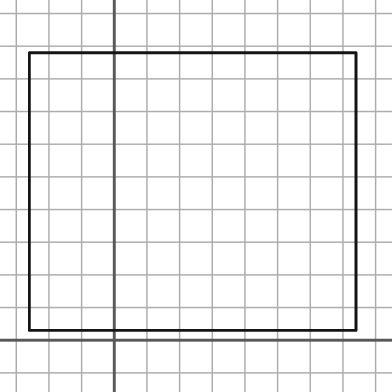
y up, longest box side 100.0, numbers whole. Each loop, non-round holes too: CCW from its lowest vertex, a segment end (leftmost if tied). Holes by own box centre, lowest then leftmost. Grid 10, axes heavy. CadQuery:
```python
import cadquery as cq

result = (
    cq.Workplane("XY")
    .moveTo(-26.0, 3.0)
    .lineTo(74.0, 3.0)
    .lineTo(74.0, 88.0)
    .lineTo(-26.0, 88.0)
    .close()
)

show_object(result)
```